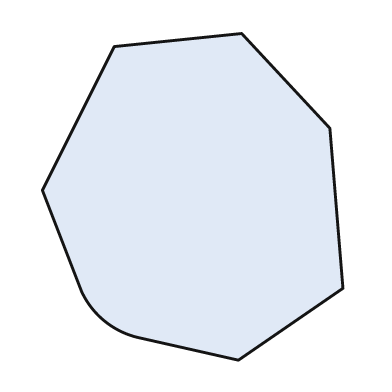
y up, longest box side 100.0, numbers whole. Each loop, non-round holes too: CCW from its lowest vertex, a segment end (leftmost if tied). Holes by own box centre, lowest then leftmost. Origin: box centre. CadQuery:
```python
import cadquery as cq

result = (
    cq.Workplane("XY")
    .moveTo(14.0, -50.0)
    .lineTo(46.0, -28.0)
    .lineTo(42.0, 21.0)
    .lineTo(15.0, 50.0)
    .lineTo(-24.0, 46.0)
    .lineTo(-46.0, 2.0)
    .lineTo(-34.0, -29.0)
    .threePointArc((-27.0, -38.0), (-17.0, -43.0))
    .close()
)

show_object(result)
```